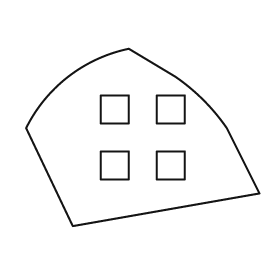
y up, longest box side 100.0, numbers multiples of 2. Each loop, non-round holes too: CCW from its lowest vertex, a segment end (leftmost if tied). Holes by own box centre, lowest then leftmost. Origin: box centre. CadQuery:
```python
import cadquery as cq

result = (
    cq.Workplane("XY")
    .moveTo(-30.0, -38.0)
    .lineTo(50.0, -24.0)
    .lineTo(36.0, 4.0)
    .threePointArc((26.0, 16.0), (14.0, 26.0))
    .lineTo(-6.0, 38.0)
    .threePointArc((-32.0, 26.0), (-50.0, 4.0))
    .close()
    .moveTo(-18.0, -18.0)
    .lineTo(-6.0, -18.0)
    .lineTo(-6.0, -6.0)
    .lineTo(-18.0, -6.0)
    .close()
    .moveTo(6.0, -18.0)
    .lineTo(18.0, -18.0)
    .lineTo(18.0, -6.0)
    .lineTo(6.0, -6.0)
    .close()
    .moveTo(-18.0, 6.0)
    .lineTo(-6.0, 6.0)
    .lineTo(-6.0, 18.0)
    .lineTo(-18.0, 18.0)
    .close()
    .moveTo(6.0, 6.0)
    .lineTo(18.0, 6.0)
    .lineTo(18.0, 18.0)
    .lineTo(6.0, 18.0)
    .close()
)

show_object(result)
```